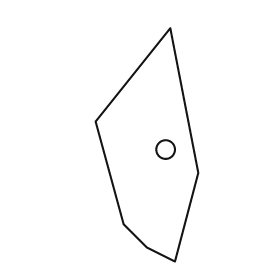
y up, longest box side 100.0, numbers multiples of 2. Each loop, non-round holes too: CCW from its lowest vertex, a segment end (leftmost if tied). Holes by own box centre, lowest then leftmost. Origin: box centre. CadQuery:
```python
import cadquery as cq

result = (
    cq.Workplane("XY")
    .moveTo(12.0, -50.0)
    .lineTo(22.0, -12.0)
    .lineTo(10.0, 50.0)
    .lineTo(-22.0, 10.0)
    .lineTo(-10.0, -34.0)
    .lineTo(0.0, -44.0)
    .close()
    .moveTo(8.0, -2.0)
    .circle(4.0)
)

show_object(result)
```